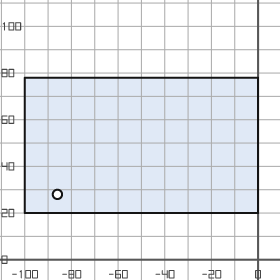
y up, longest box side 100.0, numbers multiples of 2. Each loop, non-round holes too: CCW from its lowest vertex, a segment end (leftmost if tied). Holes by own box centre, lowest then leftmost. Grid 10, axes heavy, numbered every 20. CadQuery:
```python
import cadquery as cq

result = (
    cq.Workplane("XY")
    .moveTo(-100.0, 20.0)
    .lineTo(0.0, 20.0)
    .lineTo(0.0, 78.0)
    .lineTo(-100.0, 78.0)
    .close()
    .moveTo(-86.0, 28.0)
    .circle(2.0)
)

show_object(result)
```